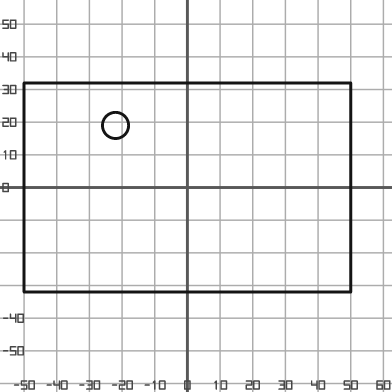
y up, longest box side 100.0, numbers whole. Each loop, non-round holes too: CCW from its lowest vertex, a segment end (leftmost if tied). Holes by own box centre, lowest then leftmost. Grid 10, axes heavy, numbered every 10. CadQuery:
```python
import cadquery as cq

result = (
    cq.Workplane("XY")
    .moveTo(-50.0, -32.0)
    .lineTo(50.0, -32.0)
    .lineTo(50.0, 32.0)
    .lineTo(-50.0, 32.0)
    .close()
    .moveTo(-22.0, 19.0)
    .circle(4.0)
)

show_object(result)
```